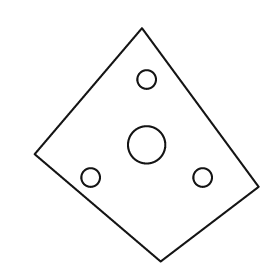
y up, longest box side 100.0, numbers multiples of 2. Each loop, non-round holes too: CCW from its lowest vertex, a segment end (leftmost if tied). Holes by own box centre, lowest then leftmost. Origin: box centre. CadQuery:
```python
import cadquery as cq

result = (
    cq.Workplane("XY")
    .moveTo(6.0, -50.0)
    .lineTo(48.0, -18.0)
    .lineTo(-2.0, 50.0)
    .lineTo(-48.0, -4.0)
    .close()
    .moveTo(-24.0, -14.0)
    .circle(4.0)
    .moveTo(24.0, -14.0)
    .circle(4.0)
    .moveTo(0.0, 0.0)
    .circle(8.0)
    .moveTo(0.0, 28.0)
    .circle(4.0)
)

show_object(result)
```